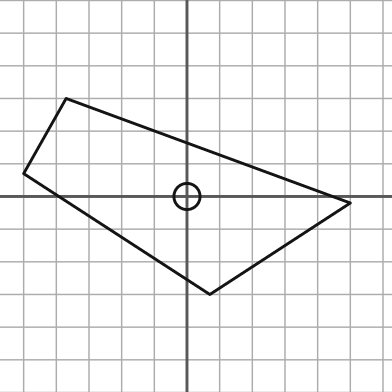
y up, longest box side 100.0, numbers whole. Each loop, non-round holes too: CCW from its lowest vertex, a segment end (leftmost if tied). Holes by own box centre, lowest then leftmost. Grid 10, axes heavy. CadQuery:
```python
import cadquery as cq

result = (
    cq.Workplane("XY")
    .moveTo(7.0, -30.0)
    .lineTo(50.0, -2.0)
    .lineTo(-37.0, 30.0)
    .lineTo(-50.0, 7.0)
    .close()
    .moveTo(0.0, 0.0)
    .circle(4.0)
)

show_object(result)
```